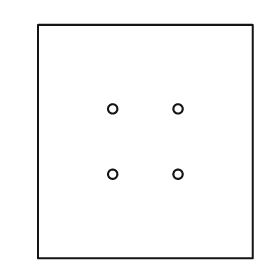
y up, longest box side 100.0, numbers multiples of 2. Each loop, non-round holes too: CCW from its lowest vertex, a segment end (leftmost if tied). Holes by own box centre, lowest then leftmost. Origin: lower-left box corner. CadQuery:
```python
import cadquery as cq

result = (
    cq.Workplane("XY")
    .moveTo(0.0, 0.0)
    .lineTo(92.0, 0.0)
    .lineTo(92.0, 100.0)
    .lineTo(0.0, 100.0)
    .close()
    .moveTo(32.0, 36.0)
    .circle(2.0)
    .moveTo(60.0, 36.0)
    .circle(2.0)
    .moveTo(32.0, 64.0)
    .circle(2.0)
    .moveTo(60.0, 64.0)
    .circle(2.0)
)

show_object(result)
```